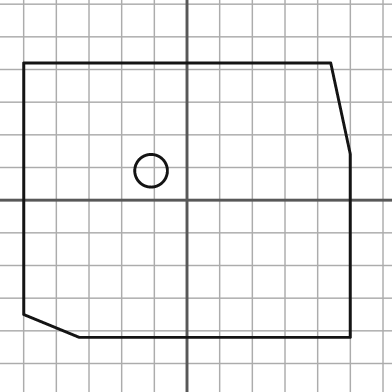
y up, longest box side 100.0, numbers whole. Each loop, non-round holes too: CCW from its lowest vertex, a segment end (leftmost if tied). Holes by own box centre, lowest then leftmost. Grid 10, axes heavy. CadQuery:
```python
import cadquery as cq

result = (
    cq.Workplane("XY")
    .moveTo(-33.0, -42.0)
    .lineTo(50.0, -42.0)
    .lineTo(50.0, 14.0)
    .lineTo(44.0, 42.0)
    .lineTo(-50.0, 42.0)
    .lineTo(-50.0, -35.0)
    .close()
    .moveTo(-11.0, 9.0)
    .circle(5.0)
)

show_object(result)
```